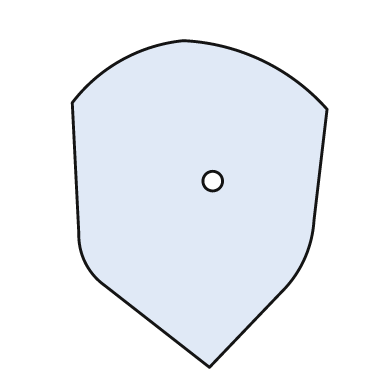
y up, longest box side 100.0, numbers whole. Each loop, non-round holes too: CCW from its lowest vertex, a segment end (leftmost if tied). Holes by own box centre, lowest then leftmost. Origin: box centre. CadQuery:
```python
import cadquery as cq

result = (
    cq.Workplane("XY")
    .moveTo(3.0, -50.0)
    .lineTo(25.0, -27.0)
    .threePointArc((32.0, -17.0), (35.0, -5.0))
    .lineTo(39.0, 29.0)
    .threePointArc((19.0, 44.0), (-5.0, 50.0))
    .threePointArc((-24.0, 44.0), (-39.0, 31.0))
    .lineTo(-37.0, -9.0)
    .threePointArc((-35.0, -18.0), (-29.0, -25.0))
    .close()
    .moveTo(4.0, 7.0)
    .circle(3.0)
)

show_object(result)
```